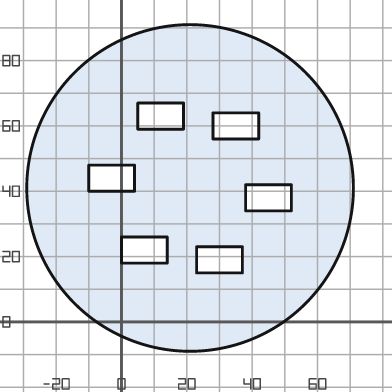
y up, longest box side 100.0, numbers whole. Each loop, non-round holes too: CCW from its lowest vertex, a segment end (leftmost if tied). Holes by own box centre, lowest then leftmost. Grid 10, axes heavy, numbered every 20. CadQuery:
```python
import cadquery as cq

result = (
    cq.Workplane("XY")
    .moveTo(21.0, 41.0)
    .circle(50.0)
    .moveTo(23.0, 15.0)
    .lineTo(37.0, 15.0)
    .lineTo(37.0, 23.0)
    .lineTo(23.0, 23.0)
    .close()
    .moveTo(0.0, 18.0)
    .lineTo(14.0, 18.0)
    .lineTo(14.0, 26.0)
    .lineTo(0.0, 26.0)
    .close()
    .moveTo(38.0, 34.0)
    .lineTo(52.0, 34.0)
    .lineTo(52.0, 42.0)
    .lineTo(38.0, 42.0)
    .close()
    .moveTo(-10.0, 40.0)
    .lineTo(4.0, 40.0)
    .lineTo(4.0, 48.0)
    .lineTo(-10.0, 48.0)
    .close()
    .moveTo(28.0, 56.0)
    .lineTo(42.0, 56.0)
    .lineTo(42.0, 64.0)
    .lineTo(28.0, 64.0)
    .close()
    .moveTo(5.0, 59.0)
    .lineTo(19.0, 59.0)
    .lineTo(19.0, 67.0)
    .lineTo(5.0, 67.0)
    .close()
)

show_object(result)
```